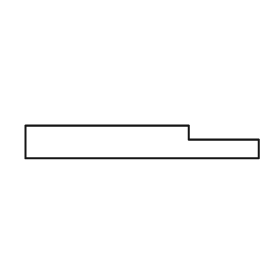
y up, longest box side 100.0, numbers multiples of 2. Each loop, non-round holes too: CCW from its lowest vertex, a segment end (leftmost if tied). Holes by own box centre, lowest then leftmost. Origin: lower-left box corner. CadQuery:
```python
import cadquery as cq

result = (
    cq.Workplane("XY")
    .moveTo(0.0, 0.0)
    .lineTo(100.0, 0.0)
    .lineTo(100.0, 8.0)
    .lineTo(70.0, 8.0)
    .lineTo(70.0, 14.0)
    .lineTo(0.0, 14.0)
    .close()
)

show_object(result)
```